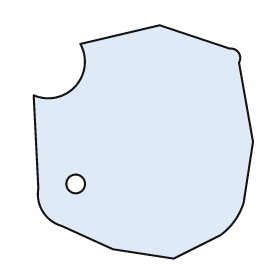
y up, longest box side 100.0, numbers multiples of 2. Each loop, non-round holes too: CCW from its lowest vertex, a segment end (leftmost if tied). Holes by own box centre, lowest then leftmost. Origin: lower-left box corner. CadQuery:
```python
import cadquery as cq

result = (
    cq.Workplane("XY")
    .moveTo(60.0, 0.0)
    .lineTo(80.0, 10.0)
    .threePointArc((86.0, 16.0), (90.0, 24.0))
    .lineTo(94.0, 50.0)
    .lineTo(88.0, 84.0)
    .threePointArc((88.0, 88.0), (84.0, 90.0))
    .lineTo(54.0, 100.0)
    .lineTo(20.0, 92.0)
    .threePointArc((18.0, 74.0), (0.0, 70.0))
    .lineTo(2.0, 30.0)
    .threePointArc((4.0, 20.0), (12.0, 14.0))
    .lineTo(34.0, 4.0)
    .close()
    .moveTo(18.0, 32.0)
    .circle(4.0)
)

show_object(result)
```